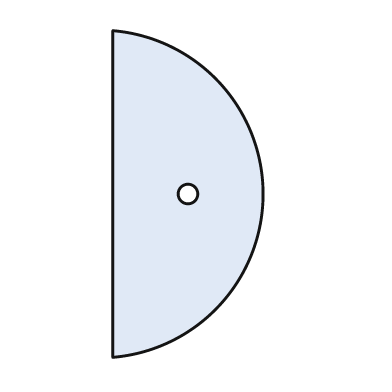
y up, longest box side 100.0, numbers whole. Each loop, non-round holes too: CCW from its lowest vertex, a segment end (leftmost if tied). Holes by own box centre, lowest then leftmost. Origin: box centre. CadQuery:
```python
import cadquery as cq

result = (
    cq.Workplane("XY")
    .moveTo(-23.0, -50.0)
    .threePointArc((23.0, 0.0), (-23.0, 50.0))
    .close()
    .moveTo(0.0, 0.0)
    .circle(3.0)
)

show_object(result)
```